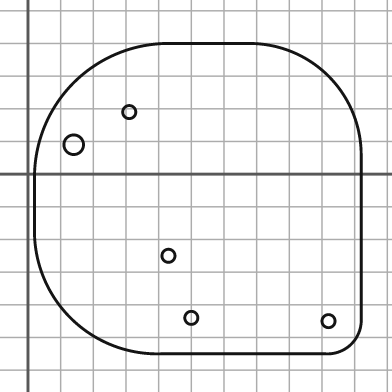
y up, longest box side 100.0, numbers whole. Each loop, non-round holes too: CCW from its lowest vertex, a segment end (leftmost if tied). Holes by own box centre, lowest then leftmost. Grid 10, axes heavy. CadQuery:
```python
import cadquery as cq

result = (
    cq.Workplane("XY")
    .moveTo(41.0, -55.0)
    .lineTo(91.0, -55.0)
    .threePointArc((99.0, -52.0), (102.0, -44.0))
    .lineTo(102.0, 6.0)
    .threePointArc((92.0, 30.0), (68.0, 40.0))
    .lineTo(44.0, 40.0)
    .threePointArc((14.0, 28.0), (2.0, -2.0))
    .lineTo(2.0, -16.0)
    .threePointArc((13.0, -44.0), (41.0, -55.0))
    .close()
    .moveTo(92.0, -45.0)
    .circle(2.0)
    .moveTo(50.0, -44.0)
    .circle(2.0)
    .moveTo(43.0, -25.0)
    .circle(2.0)
    .moveTo(14.0, 9.0)
    .circle(3.0)
    .moveTo(31.0, 19.0)
    .circle(2.0)
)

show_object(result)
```